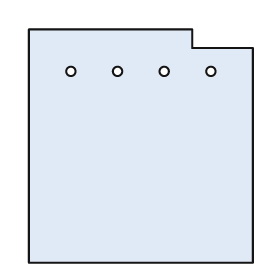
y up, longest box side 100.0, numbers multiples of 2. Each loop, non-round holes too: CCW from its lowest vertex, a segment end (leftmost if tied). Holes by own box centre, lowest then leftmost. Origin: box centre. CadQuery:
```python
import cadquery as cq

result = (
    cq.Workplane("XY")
    .moveTo(-48.0, -50.0)
    .lineTo(48.0, -50.0)
    .lineTo(48.0, 42.0)
    .lineTo(22.0, 42.0)
    .lineTo(22.0, 50.0)
    .lineTo(-48.0, 50.0)
    .close()
    .moveTo(-30.0, 32.0)
    .circle(2.0)
    .moveTo(-10.0, 32.0)
    .circle(2.0)
    .moveTo(10.0, 32.0)
    .circle(2.0)
    .moveTo(30.0, 32.0)
    .circle(2.0)
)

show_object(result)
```